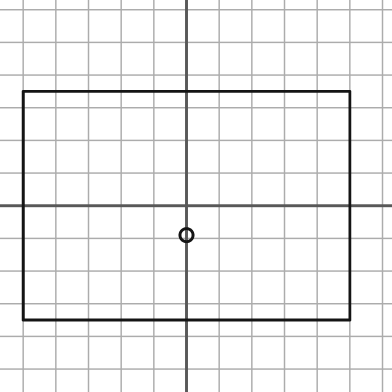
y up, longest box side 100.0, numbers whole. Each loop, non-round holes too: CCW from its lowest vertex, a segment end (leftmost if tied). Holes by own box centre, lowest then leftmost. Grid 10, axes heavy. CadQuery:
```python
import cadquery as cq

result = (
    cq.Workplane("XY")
    .moveTo(-50.0, -35.0)
    .lineTo(50.0, -35.0)
    .lineTo(50.0, 35.0)
    .lineTo(-50.0, 35.0)
    .close()
    .moveTo(0.0, -9.0)
    .circle(2.0)
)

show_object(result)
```